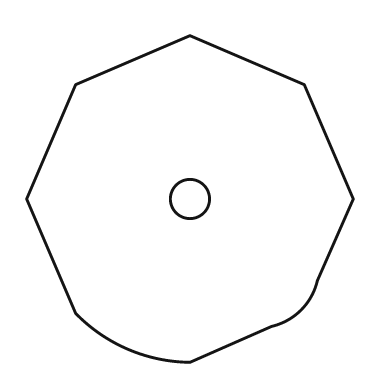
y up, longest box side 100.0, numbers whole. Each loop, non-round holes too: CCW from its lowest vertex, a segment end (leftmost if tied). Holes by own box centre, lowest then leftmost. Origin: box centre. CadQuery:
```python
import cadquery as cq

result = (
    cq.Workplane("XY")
    .moveTo(0.0, -50.0)
    .lineTo(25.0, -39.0)
    .threePointArc((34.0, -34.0), (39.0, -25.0))
    .lineTo(50.0, 0.0)
    .lineTo(35.0, 35.0)
    .lineTo(0.0, 50.0)
    .lineTo(-35.0, 35.0)
    .lineTo(-50.0, 0.0)
    .lineTo(-35.0, -35.0)
    .threePointArc((-19.0, -46.0), (0.0, -50.0))
    .close()
    .moveTo(0.0, 0.0)
    .circle(6.0)
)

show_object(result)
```